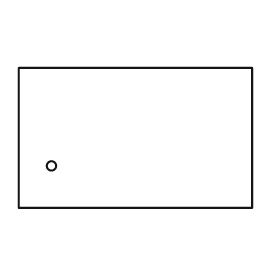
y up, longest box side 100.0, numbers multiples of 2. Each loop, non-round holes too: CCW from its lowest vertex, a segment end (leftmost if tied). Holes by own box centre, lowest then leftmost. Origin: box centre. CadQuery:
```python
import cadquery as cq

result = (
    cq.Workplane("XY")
    .moveTo(-50.0, -30.0)
    .lineTo(50.0, -30.0)
    .lineTo(50.0, 30.0)
    .lineTo(-50.0, 30.0)
    .close()
    .moveTo(-36.0, -12.0)
    .circle(2.0)
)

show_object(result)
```